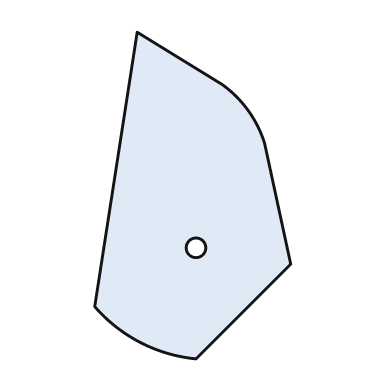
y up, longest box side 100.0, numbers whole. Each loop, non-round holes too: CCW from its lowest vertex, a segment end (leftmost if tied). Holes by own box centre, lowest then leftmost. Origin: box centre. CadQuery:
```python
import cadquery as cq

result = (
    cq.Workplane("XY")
    .moveTo(1.0, -50.0)
    .lineTo(30.0, -21.0)
    .lineTo(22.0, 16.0)
    .threePointArc((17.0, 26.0), (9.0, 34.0))
    .lineTo(-17.0, 50.0)
    .lineTo(-30.0, -34.0)
    .threePointArc((-16.0, -45.0), (1.0, -50.0))
    .close()
    .moveTo(1.0, -16.0)
    .circle(3.0)
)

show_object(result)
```